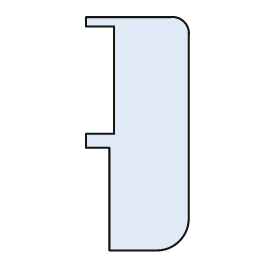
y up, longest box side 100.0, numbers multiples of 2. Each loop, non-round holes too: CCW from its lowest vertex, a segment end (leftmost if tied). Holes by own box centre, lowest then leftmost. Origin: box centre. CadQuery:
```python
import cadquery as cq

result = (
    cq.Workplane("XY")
    .moveTo(-12.0, -50.0)
    .lineTo(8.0, -50.0)
    .threePointArc((18.0, -46.0), (22.0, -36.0))
    .lineTo(22.0, 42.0)
    .threePointArc((20.0, 48.0), (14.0, 50.0))
    .lineTo(-22.0, 50.0)
    .lineTo(-22.0, 46.0)
    .lineTo(-10.0, 46.0)
    .lineTo(-10.0, 0.0)
    .lineTo(-22.0, 0.0)
    .lineTo(-22.0, -6.0)
    .lineTo(-12.0, -6.0)
    .close()
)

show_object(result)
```